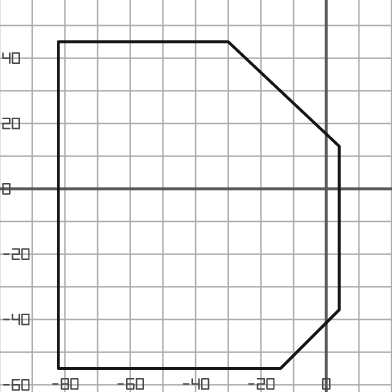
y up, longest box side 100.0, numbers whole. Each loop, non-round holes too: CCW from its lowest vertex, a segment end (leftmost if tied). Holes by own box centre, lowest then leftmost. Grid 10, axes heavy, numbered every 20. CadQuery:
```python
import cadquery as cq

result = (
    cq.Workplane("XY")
    .moveTo(-82.0, -55.0)
    .lineTo(-14.0, -55.0)
    .lineTo(4.0, -37.0)
    .lineTo(4.0, 13.0)
    .lineTo(-30.0, 45.0)
    .lineTo(-82.0, 45.0)
    .close()
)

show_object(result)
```